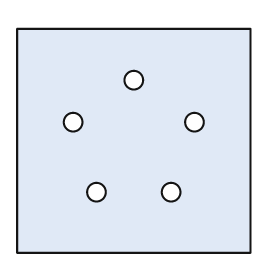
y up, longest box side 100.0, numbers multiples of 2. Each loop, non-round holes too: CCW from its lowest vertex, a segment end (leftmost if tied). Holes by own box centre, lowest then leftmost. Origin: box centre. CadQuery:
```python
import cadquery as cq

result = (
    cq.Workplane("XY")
    .moveTo(-50.0, -48.0)
    .lineTo(50.0, -48.0)
    .lineTo(50.0, 48.0)
    .lineTo(-50.0, 48.0)
    .close()
    .moveTo(-16.0, -22.0)
    .circle(4.0)
    .moveTo(16.0, -22.0)
    .circle(4.0)
    .moveTo(-26.0, 8.0)
    .circle(4.0)
    .moveTo(26.0, 8.0)
    .circle(4.0)
    .moveTo(0.0, 26.0)
    .circle(4.0)
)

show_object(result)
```